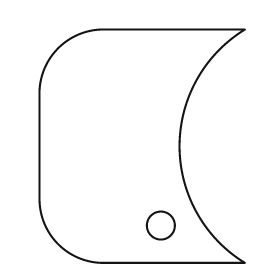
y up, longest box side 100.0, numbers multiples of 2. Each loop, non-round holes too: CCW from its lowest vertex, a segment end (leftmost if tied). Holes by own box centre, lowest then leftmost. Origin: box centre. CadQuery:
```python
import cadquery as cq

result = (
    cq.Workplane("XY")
    .moveTo(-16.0, -50.0)
    .lineTo(44.0, -50.0)
    .threePointArc((16.0, 0.0), (44.0, 50.0))
    .lineTo(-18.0, 50.0)
    .threePointArc((-36.0, 42.0), (-44.0, 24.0))
    .lineTo(-44.0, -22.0)
    .threePointArc((-36.0, -42.0), (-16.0, -50.0))
    .close()
    .moveTo(8.0, -34.0)
    .circle(6.0)
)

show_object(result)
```